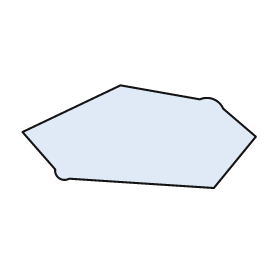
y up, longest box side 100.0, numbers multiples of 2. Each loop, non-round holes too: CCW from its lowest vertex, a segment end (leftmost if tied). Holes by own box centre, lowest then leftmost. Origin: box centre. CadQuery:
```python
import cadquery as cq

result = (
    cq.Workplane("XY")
    .moveTo(32.0, -22.0)
    .lineTo(50.0, 0.0)
    .lineTo(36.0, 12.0)
    .threePointArc((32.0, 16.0), (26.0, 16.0))
    .lineTo(-8.0, 22.0)
    .lineTo(-50.0, 2.0)
    .lineTo(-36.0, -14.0)
    .threePointArc((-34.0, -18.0), (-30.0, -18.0))
    .close()
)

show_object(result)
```